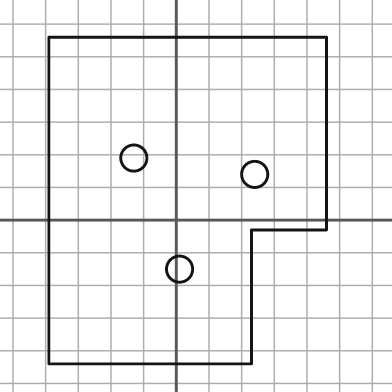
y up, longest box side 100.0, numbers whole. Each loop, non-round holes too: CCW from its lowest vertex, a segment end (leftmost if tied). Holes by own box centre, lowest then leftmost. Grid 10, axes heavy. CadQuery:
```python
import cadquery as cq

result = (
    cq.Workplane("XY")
    .moveTo(-39.0, -44.0)
    .lineTo(23.0, -44.0)
    .lineTo(23.0, -3.0)
    .lineTo(46.0, -3.0)
    .lineTo(46.0, 56.0)
    .lineTo(-39.0, 56.0)
    .close()
    .moveTo(1.0, -15.0)
    .circle(4.0)
    .moveTo(24.0, 14.0)
    .circle(4.0)
    .moveTo(-13.0, 19.0)
    .circle(4.0)
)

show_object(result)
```